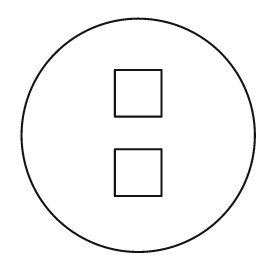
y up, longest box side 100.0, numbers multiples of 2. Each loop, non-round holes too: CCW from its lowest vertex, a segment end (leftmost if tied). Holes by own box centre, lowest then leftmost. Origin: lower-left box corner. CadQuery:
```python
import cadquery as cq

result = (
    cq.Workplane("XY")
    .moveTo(50.0, 50.0)
    .circle(50.0)
    .moveTo(40.0, 24.0)
    .lineTo(60.0, 24.0)
    .lineTo(60.0, 44.0)
    .lineTo(40.0, 44.0)
    .close()
    .moveTo(40.0, 58.0)
    .lineTo(60.0, 58.0)
    .lineTo(60.0, 78.0)
    .lineTo(40.0, 78.0)
    .close()
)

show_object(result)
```